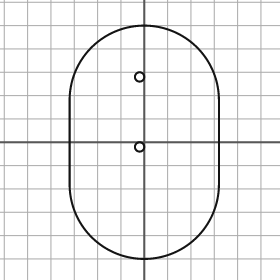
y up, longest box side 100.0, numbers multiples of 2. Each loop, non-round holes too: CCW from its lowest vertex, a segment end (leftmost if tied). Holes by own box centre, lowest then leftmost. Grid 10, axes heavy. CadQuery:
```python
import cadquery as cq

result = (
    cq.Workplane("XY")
    .moveTo(-32.0, -18.0)
    .threePointArc((0.0, -50.0), (32.0, -18.0))
    .lineTo(32.0, 18.0)
    .threePointArc((0.0, 50.0), (-32.0, 18.0))
    .close()
    .moveTo(-2.0, -2.0)
    .circle(2.0)
    .moveTo(-2.0, 28.0)
    .circle(2.0)
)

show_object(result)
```